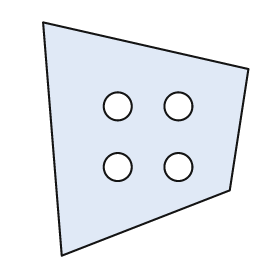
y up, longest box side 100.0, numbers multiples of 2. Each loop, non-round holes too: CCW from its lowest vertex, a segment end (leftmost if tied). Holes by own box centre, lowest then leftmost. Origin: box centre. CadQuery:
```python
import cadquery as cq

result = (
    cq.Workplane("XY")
    .moveTo(-36.0, -50.0)
    .lineTo(36.0, -22.0)
    .lineTo(44.0, 30.0)
    .lineTo(-44.0, 50.0)
    .close()
    .moveTo(-12.0, -12.0)
    .circle(6.0)
    .moveTo(14.0, -12.0)
    .circle(6.0)
    .moveTo(-12.0, 14.0)
    .circle(6.0)
    .moveTo(14.0, 14.0)
    .circle(6.0)
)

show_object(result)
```